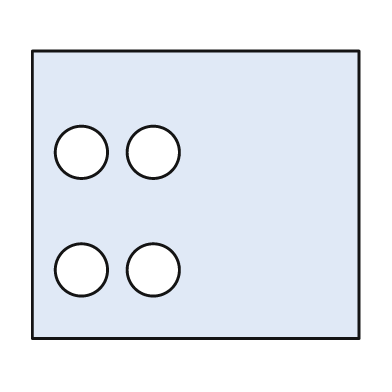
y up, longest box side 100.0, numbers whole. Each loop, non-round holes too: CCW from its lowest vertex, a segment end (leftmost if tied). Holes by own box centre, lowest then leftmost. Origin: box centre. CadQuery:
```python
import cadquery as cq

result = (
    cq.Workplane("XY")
    .moveTo(-50.0, -44.0)
    .lineTo(50.0, -44.0)
    .lineTo(50.0, 44.0)
    .lineTo(-50.0, 44.0)
    .close()
    .moveTo(-35.0, -23.0)
    .circle(8.0)
    .moveTo(-13.0, -23.0)
    .circle(8.0)
    .moveTo(-35.0, 13.0)
    .circle(8.0)
    .moveTo(-13.0, 13.0)
    .circle(8.0)
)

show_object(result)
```